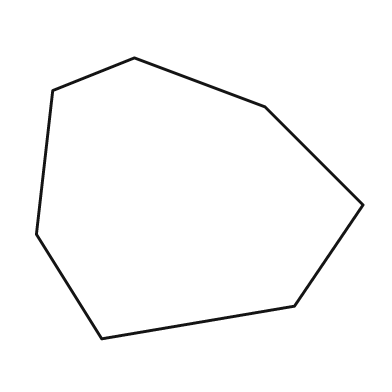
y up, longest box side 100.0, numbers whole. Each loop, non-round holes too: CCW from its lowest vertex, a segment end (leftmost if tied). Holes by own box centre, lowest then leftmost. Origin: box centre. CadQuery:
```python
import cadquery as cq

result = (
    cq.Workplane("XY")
    .moveTo(-30.0, -43.0)
    .lineTo(29.0, -33.0)
    .lineTo(50.0, -2.0)
    .lineTo(20.0, 28.0)
    .lineTo(-20.0, 43.0)
    .lineTo(-45.0, 33.0)
    .lineTo(-50.0, -11.0)
    .close()
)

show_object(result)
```